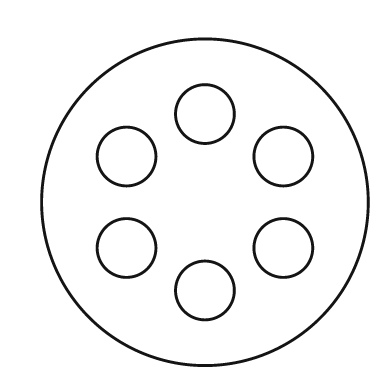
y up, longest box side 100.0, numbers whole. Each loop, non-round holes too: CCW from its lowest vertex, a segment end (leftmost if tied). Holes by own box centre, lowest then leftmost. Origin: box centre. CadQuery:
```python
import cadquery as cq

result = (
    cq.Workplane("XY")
    .moveTo(0.0, 0.0)
    .circle(50.0)
    .moveTo(0.0, -27.0)
    .circle(9.0)
    .moveTo(-24.0, -14.0)
    .circle(9.0)
    .moveTo(24.0, -14.0)
    .circle(9.0)
    .moveTo(-24.0, 14.0)
    .circle(9.0)
    .moveTo(24.0, 14.0)
    .circle(9.0)
    .moveTo(0.0, 27.0)
    .circle(9.0)
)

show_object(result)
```